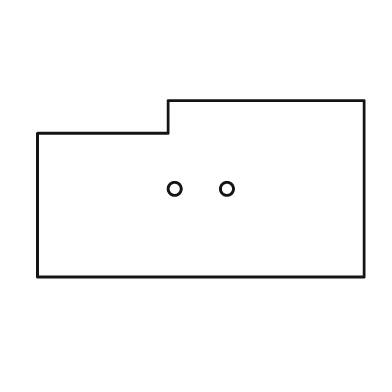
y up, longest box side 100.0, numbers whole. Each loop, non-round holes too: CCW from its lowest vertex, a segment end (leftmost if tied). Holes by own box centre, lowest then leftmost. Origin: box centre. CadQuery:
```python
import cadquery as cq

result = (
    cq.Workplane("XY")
    .moveTo(-50.0, -27.0)
    .lineTo(50.0, -27.0)
    .lineTo(50.0, 27.0)
    .lineTo(-10.0, 27.0)
    .lineTo(-10.0, 17.0)
    .lineTo(-50.0, 17.0)
    .close()
    .moveTo(-8.0, 0.0)
    .circle(2.0)
    .moveTo(8.0, 0.0)
    .circle(2.0)
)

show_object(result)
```